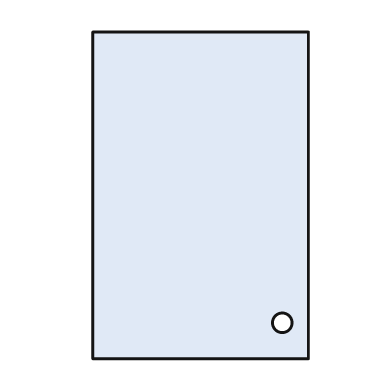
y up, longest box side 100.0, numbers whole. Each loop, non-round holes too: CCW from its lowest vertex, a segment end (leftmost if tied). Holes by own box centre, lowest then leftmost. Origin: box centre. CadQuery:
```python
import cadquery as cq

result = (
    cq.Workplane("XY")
    .moveTo(-33.0, -50.0)
    .lineTo(33.0, -50.0)
    .lineTo(33.0, 50.0)
    .lineTo(-33.0, 50.0)
    .close()
    .moveTo(25.0, -39.0)
    .circle(3.0)
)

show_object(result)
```